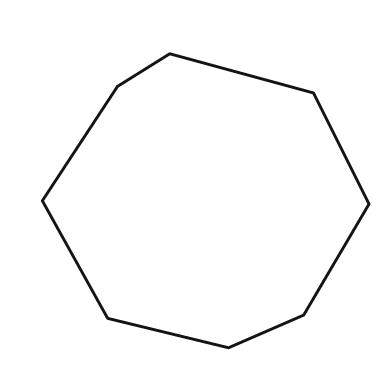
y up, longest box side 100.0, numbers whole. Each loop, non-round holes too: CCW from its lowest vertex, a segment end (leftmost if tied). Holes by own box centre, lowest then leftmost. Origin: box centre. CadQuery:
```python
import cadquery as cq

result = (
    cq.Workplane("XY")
    .moveTo(7.0, -45.0)
    .lineTo(30.0, -35.0)
    .lineTo(50.0, -1.0)
    .lineTo(33.0, 33.0)
    .lineTo(-11.0, 45.0)
    .lineTo(-27.0, 35.0)
    .lineTo(-50.0, 0.0)
    .lineTo(-30.0, -36.0)
    .close()
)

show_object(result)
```